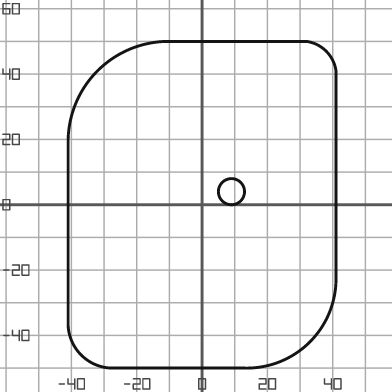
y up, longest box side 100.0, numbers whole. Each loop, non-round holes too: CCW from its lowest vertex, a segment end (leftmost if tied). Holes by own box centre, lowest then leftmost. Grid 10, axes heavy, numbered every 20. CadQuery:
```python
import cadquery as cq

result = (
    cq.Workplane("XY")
    .moveTo(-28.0, -50.0)
    .lineTo(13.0, -50.0)
    .threePointArc((33.0, -42.0), (41.0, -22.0))
    .lineTo(41.0, 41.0)
    .threePointArc((38.0, 47.0), (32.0, 50.0))
    .lineTo(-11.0, 50.0)
    .threePointArc((-32.0, 41.0), (-41.0, 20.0))
    .lineTo(-41.0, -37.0)
    .threePointArc((-37.0, -46.0), (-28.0, -50.0))
    .close()
    .moveTo(9.0, 4.0)
    .circle(4.0)
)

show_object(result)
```